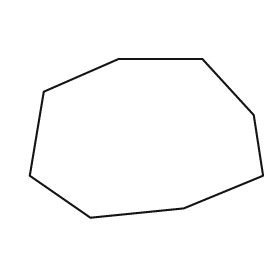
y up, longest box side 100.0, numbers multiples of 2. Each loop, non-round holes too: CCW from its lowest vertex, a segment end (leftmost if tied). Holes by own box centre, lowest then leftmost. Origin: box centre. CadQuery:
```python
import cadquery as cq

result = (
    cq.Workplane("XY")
    .moveTo(-24.0, -34.0)
    .lineTo(16.0, -30.0)
    .lineTo(50.0, -16.0)
    .lineTo(46.0, 10.0)
    .lineTo(24.0, 34.0)
    .lineTo(-12.0, 34.0)
    .lineTo(-44.0, 20.0)
    .lineTo(-50.0, -16.0)
    .close()
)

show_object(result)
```